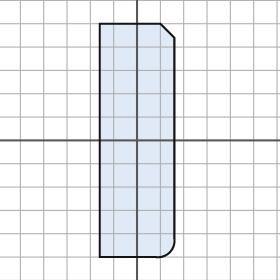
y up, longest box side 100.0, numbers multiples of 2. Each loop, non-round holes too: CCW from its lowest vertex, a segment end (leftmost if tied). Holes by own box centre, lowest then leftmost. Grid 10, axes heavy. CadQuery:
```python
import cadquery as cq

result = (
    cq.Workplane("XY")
    .moveTo(-16.0, -50.0)
    .lineTo(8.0, -50.0)
    .threePointArc((14.0, -48.0), (16.0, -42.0))
    .lineTo(16.0, 44.0)
    .lineTo(10.0, 50.0)
    .lineTo(-16.0, 50.0)
    .close()
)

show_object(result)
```